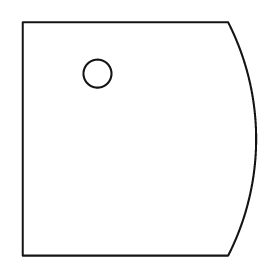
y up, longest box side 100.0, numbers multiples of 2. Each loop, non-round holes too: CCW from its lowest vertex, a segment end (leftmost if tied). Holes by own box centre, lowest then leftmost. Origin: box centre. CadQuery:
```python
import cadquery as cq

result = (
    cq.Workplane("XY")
    .moveTo(-50.0, -50.0)
    .lineTo(38.0, -50.0)
    .threePointArc((50.0, 0.0), (38.0, 50.0))
    .lineTo(-50.0, 50.0)
    .close()
    .moveTo(-18.0, 28.0)
    .circle(6.0)
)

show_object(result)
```